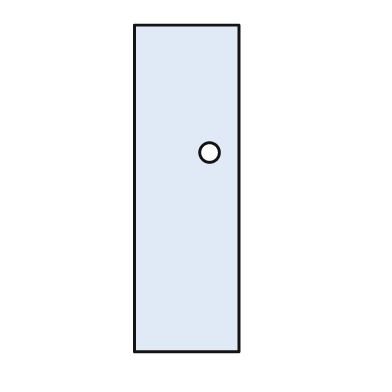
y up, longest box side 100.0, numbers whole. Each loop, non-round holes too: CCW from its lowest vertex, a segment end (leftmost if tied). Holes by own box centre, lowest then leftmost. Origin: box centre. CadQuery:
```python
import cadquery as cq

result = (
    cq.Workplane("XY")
    .moveTo(-16.0, -50.0)
    .lineTo(16.0, -50.0)
    .lineTo(16.0, 50.0)
    .lineTo(-16.0, 50.0)
    .close()
    .moveTo(7.0, 11.0)
    .circle(3.0)
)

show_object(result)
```